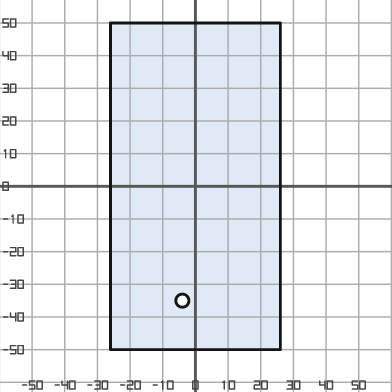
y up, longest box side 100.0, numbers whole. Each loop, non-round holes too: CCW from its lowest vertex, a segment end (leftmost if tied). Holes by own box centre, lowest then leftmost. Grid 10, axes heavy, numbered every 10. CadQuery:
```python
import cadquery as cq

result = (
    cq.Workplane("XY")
    .moveTo(-26.0, -50.0)
    .lineTo(26.0, -50.0)
    .lineTo(26.0, 50.0)
    .lineTo(-26.0, 50.0)
    .close()
    .moveTo(-4.0, -35.0)
    .circle(2.0)
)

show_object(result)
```